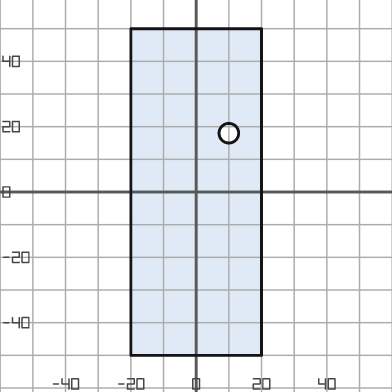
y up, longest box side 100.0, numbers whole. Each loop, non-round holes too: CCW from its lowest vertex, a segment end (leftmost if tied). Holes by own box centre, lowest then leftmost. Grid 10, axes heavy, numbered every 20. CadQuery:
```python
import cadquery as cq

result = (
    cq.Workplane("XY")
    .moveTo(-20.0, -50.0)
    .lineTo(20.0, -50.0)
    .lineTo(20.0, 50.0)
    .lineTo(-20.0, 50.0)
    .close()
    .moveTo(10.0, 18.0)
    .circle(3.0)
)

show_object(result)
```